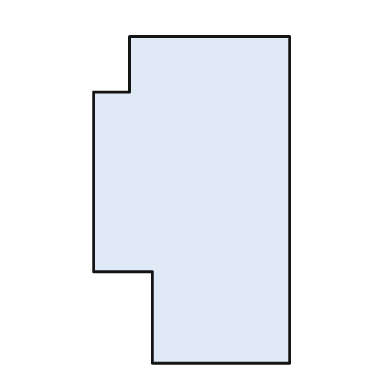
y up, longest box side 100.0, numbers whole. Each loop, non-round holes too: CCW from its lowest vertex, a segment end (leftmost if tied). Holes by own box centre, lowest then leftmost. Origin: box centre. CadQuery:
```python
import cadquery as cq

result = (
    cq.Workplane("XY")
    .moveTo(-12.0, -50.0)
    .lineTo(30.0, -50.0)
    .lineTo(30.0, 50.0)
    .lineTo(-19.0, 50.0)
    .lineTo(-19.0, 33.0)
    .lineTo(-30.0, 33.0)
    .lineTo(-30.0, -22.0)
    .lineTo(-12.0, -22.0)
    .close()
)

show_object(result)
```